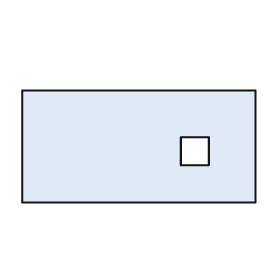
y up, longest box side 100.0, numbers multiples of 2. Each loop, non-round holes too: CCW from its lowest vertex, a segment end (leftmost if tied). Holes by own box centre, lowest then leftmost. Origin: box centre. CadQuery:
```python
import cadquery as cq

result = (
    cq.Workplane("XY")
    .moveTo(-50.0, -24.0)
    .lineTo(50.0, -24.0)
    .lineTo(50.0, 24.0)
    .lineTo(-50.0, 24.0)
    .close()
    .moveTo(18.0, -8.0)
    .lineTo(30.0, -8.0)
    .lineTo(30.0, 4.0)
    .lineTo(18.0, 4.0)
    .close()
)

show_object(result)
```